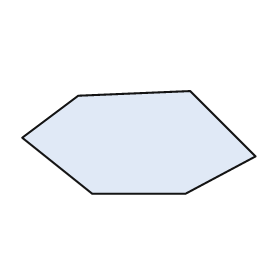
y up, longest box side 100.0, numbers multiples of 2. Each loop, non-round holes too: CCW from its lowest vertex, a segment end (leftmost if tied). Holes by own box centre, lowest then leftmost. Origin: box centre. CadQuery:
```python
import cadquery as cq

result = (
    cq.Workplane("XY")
    .moveTo(-20.0, -22.0)
    .lineTo(20.0, -22.0)
    .lineTo(50.0, -6.0)
    .lineTo(22.0, 22.0)
    .lineTo(-26.0, 20.0)
    .lineTo(-50.0, 2.0)
    .close()
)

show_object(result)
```